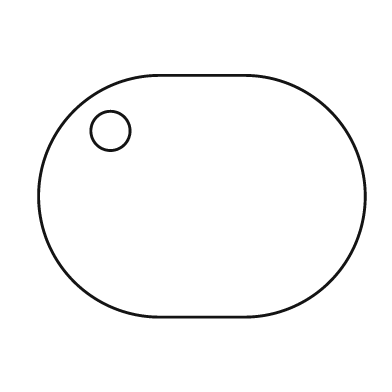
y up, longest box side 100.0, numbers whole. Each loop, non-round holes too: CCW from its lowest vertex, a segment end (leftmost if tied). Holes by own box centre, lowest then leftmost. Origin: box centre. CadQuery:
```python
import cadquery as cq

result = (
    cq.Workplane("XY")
    .moveTo(-13.0, -37.0)
    .lineTo(13.0, -37.0)
    .threePointArc((50.0, 0.0), (13.0, 37.0))
    .lineTo(-13.0, 37.0)
    .threePointArc((-50.0, 0.0), (-13.0, -37.0))
    .close()
    .moveTo(-28.0, 20.0)
    .circle(6.0)
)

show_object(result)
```